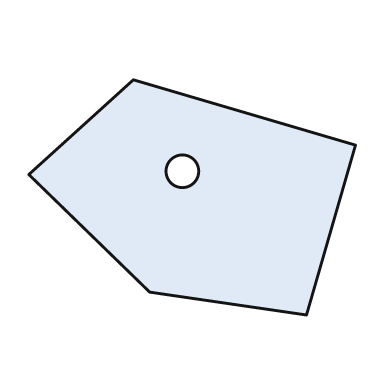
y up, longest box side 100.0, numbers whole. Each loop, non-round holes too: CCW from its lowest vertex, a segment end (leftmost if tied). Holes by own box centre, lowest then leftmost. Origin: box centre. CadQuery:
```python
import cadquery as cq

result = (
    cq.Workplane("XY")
    .moveTo(35.0, -36.0)
    .lineTo(50.0, 16.0)
    .lineTo(-18.0, 36.0)
    .lineTo(-50.0, 7.0)
    .lineTo(-13.0, -29.0)
    .close()
    .moveTo(-3.0, 8.0)
    .circle(5.0)
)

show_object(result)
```